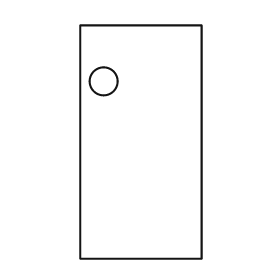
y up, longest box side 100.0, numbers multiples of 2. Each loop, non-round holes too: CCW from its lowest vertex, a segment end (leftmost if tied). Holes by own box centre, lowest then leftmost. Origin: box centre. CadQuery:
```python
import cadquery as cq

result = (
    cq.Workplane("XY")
    .moveTo(-26.0, -50.0)
    .lineTo(26.0, -50.0)
    .lineTo(26.0, 50.0)
    .lineTo(-26.0, 50.0)
    .close()
    .moveTo(-16.0, 26.0)
    .circle(6.0)
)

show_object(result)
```